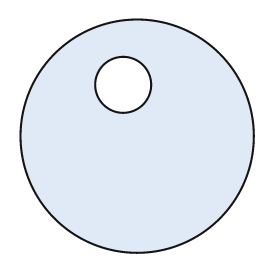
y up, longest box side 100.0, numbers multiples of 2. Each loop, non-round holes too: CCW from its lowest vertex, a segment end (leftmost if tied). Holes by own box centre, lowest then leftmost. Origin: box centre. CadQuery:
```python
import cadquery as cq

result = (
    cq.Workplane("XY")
    .moveTo(0.0, 0.0)
    .circle(50.0)
    .moveTo(-6.0, 22.0)
    .circle(12.0)
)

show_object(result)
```